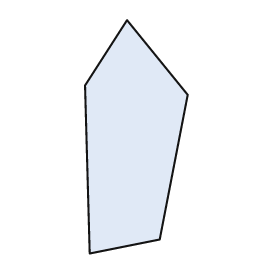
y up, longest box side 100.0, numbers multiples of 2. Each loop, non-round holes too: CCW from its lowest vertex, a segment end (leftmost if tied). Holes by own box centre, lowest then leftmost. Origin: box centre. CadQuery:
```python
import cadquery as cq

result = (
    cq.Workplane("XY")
    .moveTo(-20.0, -50.0)
    .lineTo(10.0, -44.0)
    .lineTo(22.0, 18.0)
    .lineTo(-4.0, 50.0)
    .lineTo(-22.0, 22.0)
    .close()
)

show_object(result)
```